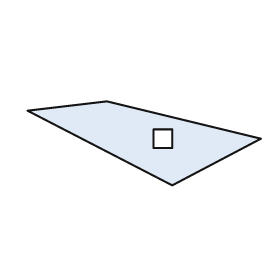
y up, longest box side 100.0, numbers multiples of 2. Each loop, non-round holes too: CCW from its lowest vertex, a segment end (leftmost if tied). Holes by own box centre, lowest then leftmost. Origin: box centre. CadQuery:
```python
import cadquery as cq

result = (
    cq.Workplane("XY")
    .moveTo(12.0, -18.0)
    .lineTo(50.0, 2.0)
    .lineTo(-16.0, 18.0)
    .lineTo(-50.0, 14.0)
    .close()
    .moveTo(4.0, -2.0)
    .lineTo(12.0, -2.0)
    .lineTo(12.0, 6.0)
    .lineTo(4.0, 6.0)
    .close()
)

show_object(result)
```